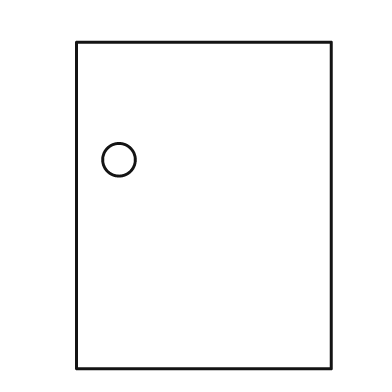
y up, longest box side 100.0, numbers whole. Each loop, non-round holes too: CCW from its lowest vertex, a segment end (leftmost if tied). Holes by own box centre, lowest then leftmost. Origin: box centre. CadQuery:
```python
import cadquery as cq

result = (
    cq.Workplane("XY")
    .moveTo(-39.0, -50.0)
    .lineTo(39.0, -50.0)
    .lineTo(39.0, 50.0)
    .lineTo(-39.0, 50.0)
    .close()
    .moveTo(-26.0, 14.0)
    .circle(5.0)
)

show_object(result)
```